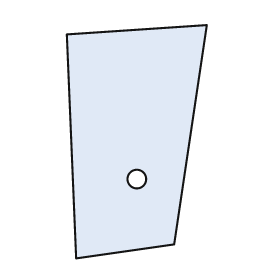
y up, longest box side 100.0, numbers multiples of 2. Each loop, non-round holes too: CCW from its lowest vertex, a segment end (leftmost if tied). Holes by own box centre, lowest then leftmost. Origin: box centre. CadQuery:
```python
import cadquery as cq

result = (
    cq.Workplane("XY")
    .moveTo(-26.0, -50.0)
    .lineTo(16.0, -44.0)
    .lineTo(30.0, 50.0)
    .lineTo(-30.0, 46.0)
    .close()
    .moveTo(0.0, -16.0)
    .circle(4.0)
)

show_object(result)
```